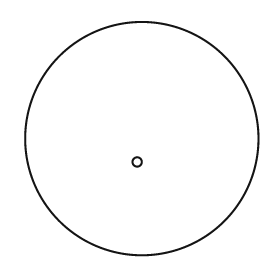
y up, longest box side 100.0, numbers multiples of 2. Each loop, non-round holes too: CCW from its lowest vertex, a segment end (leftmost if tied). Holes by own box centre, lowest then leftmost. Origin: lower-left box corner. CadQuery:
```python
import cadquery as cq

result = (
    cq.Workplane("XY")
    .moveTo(50.0, 50.0)
    .circle(50.0)
    .moveTo(48.0, 40.0)
    .circle(2.0)
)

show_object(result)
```